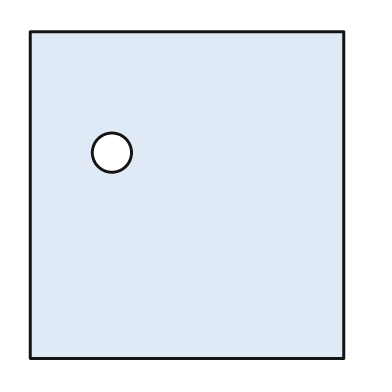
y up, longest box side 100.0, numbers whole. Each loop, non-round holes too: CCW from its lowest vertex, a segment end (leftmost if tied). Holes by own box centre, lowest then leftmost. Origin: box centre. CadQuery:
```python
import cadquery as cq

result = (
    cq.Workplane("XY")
    .moveTo(-48.0, -50.0)
    .lineTo(48.0, -50.0)
    .lineTo(48.0, 50.0)
    .lineTo(-48.0, 50.0)
    .close()
    .moveTo(-23.0, 13.0)
    .circle(6.0)
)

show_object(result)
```